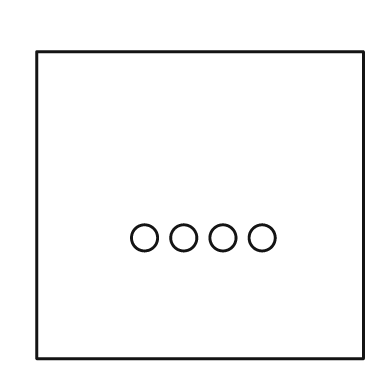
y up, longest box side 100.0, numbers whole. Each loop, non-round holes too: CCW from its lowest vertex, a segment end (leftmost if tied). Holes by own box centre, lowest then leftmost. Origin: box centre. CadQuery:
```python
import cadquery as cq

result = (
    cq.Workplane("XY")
    .moveTo(-50.0, -47.0)
    .lineTo(50.0, -47.0)
    .lineTo(50.0, 47.0)
    .lineTo(-50.0, 47.0)
    .close()
    .moveTo(-17.0, -10.0)
    .circle(4.0)
    .moveTo(-5.0, -10.0)
    .circle(4.0)
    .moveTo(7.0, -10.0)
    .circle(4.0)
    .moveTo(19.0, -10.0)
    .circle(4.0)
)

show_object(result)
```